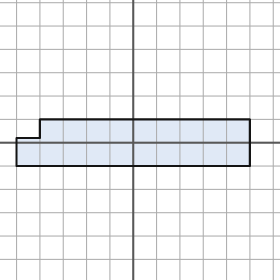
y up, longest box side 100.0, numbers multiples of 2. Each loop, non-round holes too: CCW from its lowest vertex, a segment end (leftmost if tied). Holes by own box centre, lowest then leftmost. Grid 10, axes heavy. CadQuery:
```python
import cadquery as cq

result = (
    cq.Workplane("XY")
    .moveTo(-50.0, -10.0)
    .lineTo(50.0, -10.0)
    .lineTo(50.0, 10.0)
    .lineTo(-40.0, 10.0)
    .lineTo(-40.0, 2.0)
    .lineTo(-50.0, 2.0)
    .close()
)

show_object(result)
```